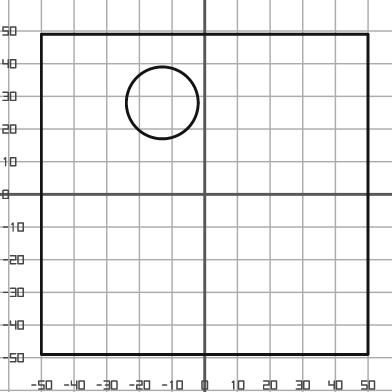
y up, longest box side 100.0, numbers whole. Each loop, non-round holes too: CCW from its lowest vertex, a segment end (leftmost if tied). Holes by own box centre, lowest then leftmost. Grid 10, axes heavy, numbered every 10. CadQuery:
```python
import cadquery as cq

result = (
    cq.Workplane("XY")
    .moveTo(-50.0, -49.0)
    .lineTo(50.0, -49.0)
    .lineTo(50.0, 49.0)
    .lineTo(-50.0, 49.0)
    .close()
    .moveTo(-13.0, 28.0)
    .circle(11.0)
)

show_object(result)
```